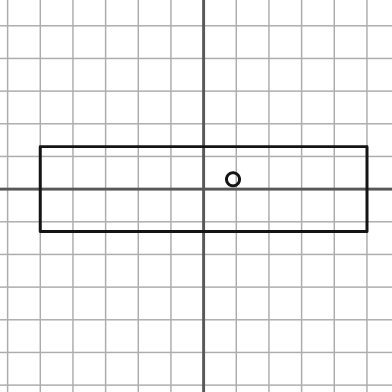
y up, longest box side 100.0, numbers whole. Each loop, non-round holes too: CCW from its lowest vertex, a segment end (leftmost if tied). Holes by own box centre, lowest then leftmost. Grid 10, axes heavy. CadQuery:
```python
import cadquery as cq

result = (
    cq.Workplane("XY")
    .moveTo(-50.0, -13.0)
    .lineTo(50.0, -13.0)
    .lineTo(50.0, 13.0)
    .lineTo(-50.0, 13.0)
    .close()
    .moveTo(9.0, 3.0)
    .circle(2.0)
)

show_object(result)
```